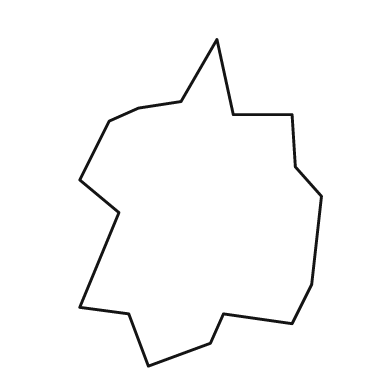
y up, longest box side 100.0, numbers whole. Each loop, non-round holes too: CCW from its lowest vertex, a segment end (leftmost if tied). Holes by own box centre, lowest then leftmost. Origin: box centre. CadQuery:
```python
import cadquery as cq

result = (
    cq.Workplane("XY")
    .moveTo(-16.0, -50.0)
    .lineTo(3.0, -43.0)
    .lineTo(7.0, -34.0)
    .lineTo(28.0, -37.0)
    .lineTo(34.0, -25.0)
    .lineTo(37.0, 2.0)
    .lineTo(29.0, 11.0)
    .lineTo(28.0, 27.0)
    .lineTo(10.0, 27.0)
    .lineTo(5.0, 50.0)
    .lineTo(-6.0, 31.0)
    .lineTo(-19.0, 29.0)
    .lineTo(-28.0, 25.0)
    .lineTo(-37.0, 7.0)
    .lineTo(-25.0, -3.0)
    .lineTo(-37.0, -32.0)
    .lineTo(-22.0, -34.0)
    .close()
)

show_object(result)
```